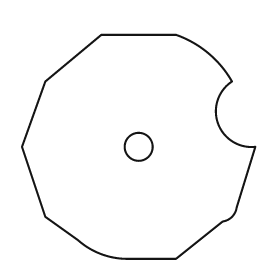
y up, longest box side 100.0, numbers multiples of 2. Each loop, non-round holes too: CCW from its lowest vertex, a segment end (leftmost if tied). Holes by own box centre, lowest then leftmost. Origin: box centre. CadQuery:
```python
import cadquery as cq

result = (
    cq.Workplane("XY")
    .moveTo(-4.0, -48.0)
    .lineTo(16.0, -48.0)
    .lineTo(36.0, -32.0)
    .threePointArc((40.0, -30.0), (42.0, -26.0))
    .lineTo(50.0, 0.0)
    .threePointArc((34.0, 10.0), (40.0, 28.0))
    .threePointArc((30.0, 40.0), (16.0, 48.0))
    .lineTo(-16.0, 48.0)
    .lineTo(-40.0, 28.0)
    .lineTo(-50.0, 0.0)
    .lineTo(-40.0, -30.0)
    .lineTo(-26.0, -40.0)
    .threePointArc((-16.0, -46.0), (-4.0, -48.0))
    .close()
    .moveTo(0.0, 0.0)
    .circle(6.0)
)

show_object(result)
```